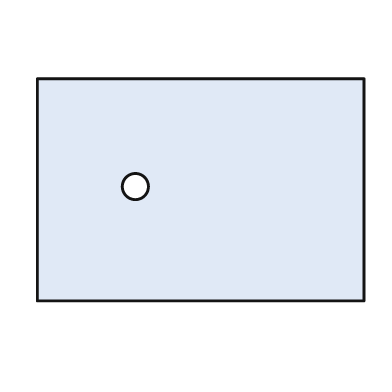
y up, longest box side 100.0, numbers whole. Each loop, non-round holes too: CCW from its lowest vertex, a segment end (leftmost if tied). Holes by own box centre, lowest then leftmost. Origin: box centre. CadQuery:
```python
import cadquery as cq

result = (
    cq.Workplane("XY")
    .moveTo(-50.0, -34.0)
    .lineTo(50.0, -34.0)
    .lineTo(50.0, 34.0)
    .lineTo(-50.0, 34.0)
    .close()
    .moveTo(-20.0, 1.0)
    .circle(4.0)
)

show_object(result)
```